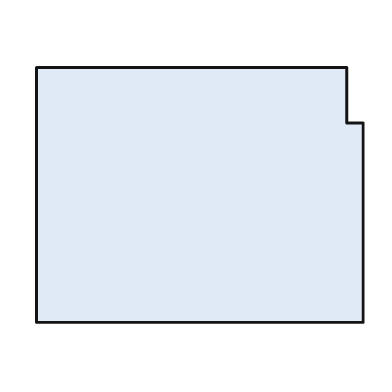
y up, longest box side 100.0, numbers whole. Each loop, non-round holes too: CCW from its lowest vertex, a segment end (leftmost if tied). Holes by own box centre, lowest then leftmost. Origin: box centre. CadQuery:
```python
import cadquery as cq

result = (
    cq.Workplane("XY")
    .moveTo(-50.0, -39.0)
    .lineTo(50.0, -39.0)
    .lineTo(50.0, 22.0)
    .lineTo(45.0, 22.0)
    .lineTo(45.0, 39.0)
    .lineTo(-50.0, 39.0)
    .close()
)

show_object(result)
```